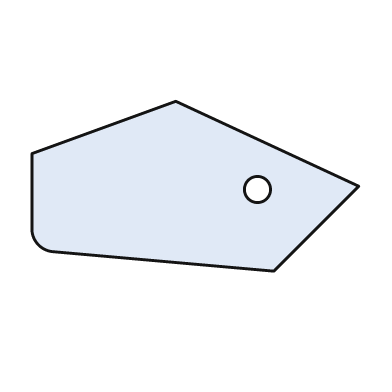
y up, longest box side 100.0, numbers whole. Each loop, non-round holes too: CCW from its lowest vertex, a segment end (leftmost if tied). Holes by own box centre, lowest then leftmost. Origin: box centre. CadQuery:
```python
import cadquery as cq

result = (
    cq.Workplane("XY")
    .moveTo(24.0, -26.0)
    .lineTo(50.0, 0.0)
    .lineTo(-6.0, 26.0)
    .lineTo(-50.0, 10.0)
    .lineTo(-50.0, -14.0)
    .threePointArc((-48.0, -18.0), (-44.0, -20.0))
    .close()
    .moveTo(19.0, -1.0)
    .circle(4.0)
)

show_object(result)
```